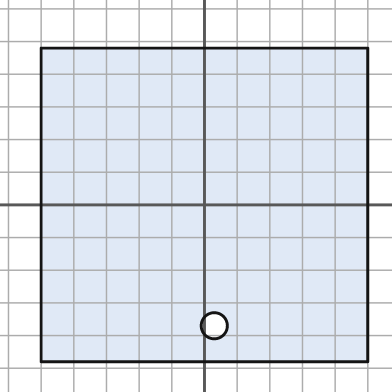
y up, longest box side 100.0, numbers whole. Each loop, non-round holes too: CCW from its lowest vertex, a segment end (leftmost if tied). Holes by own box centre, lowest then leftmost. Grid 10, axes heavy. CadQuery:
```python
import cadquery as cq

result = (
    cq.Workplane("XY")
    .moveTo(-50.0, -48.0)
    .lineTo(50.0, -48.0)
    .lineTo(50.0, 48.0)
    .lineTo(-50.0, 48.0)
    .close()
    .moveTo(3.0, -37.0)
    .circle(4.0)
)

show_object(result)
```